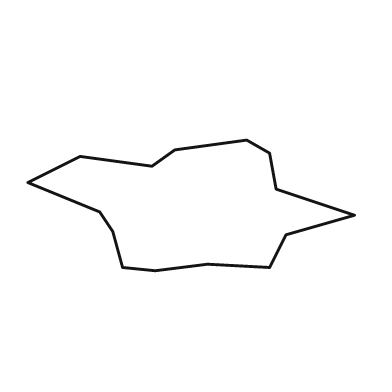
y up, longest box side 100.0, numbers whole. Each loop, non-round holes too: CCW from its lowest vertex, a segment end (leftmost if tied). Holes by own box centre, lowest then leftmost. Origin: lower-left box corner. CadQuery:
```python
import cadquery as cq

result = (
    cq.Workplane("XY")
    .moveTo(39.0, 0.0)
    .lineTo(55.0, 2.0)
    .lineTo(74.0, 1.0)
    .lineTo(79.0, 11.0)
    .lineTo(100.0, 17.0)
    .lineTo(76.0, 25.0)
    .lineTo(74.0, 36.0)
    .lineTo(67.0, 40.0)
    .lineTo(45.0, 37.0)
    .lineTo(38.0, 32.0)
    .lineTo(16.0, 35.0)
    .lineTo(0.0, 27.0)
    .lineTo(22.0, 18.0)
    .lineTo(26.0, 12.0)
    .lineTo(29.0, 1.0)
    .close()
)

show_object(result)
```